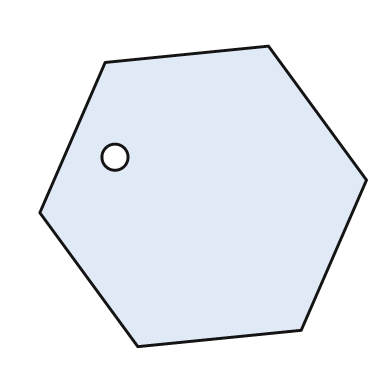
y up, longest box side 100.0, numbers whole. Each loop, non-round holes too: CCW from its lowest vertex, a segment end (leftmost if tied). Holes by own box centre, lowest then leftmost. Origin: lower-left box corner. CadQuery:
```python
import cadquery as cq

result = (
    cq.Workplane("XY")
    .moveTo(30.0, 0.0)
    .lineTo(80.0, 5.0)
    .lineTo(100.0, 51.0)
    .lineTo(70.0, 92.0)
    .lineTo(20.0, 87.0)
    .lineTo(0.0, 41.0)
    .close()
    .moveTo(23.0, 58.0)
    .circle(4.0)
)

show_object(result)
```